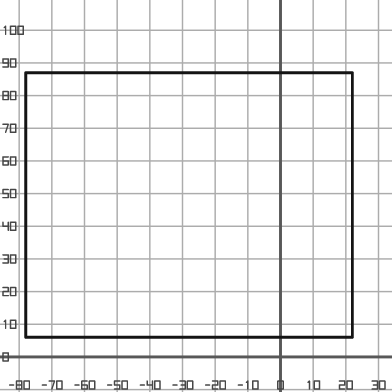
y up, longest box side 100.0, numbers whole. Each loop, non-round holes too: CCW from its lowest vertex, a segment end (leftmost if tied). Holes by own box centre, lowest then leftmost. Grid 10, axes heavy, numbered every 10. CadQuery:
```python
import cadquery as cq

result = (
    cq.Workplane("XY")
    .moveTo(-78.0, 6.0)
    .lineTo(22.0, 6.0)
    .lineTo(22.0, 87.0)
    .lineTo(-78.0, 87.0)
    .close()
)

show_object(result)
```